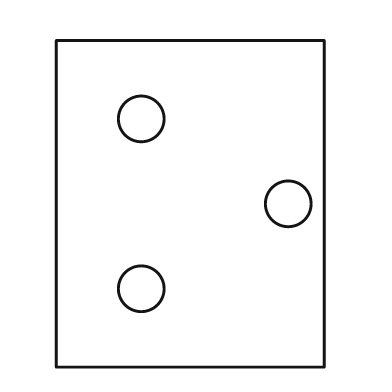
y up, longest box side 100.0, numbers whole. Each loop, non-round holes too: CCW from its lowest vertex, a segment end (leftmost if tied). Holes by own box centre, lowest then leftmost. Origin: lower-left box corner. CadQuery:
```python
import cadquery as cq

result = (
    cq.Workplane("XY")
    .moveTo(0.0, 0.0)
    .lineTo(82.0, 0.0)
    .lineTo(82.0, 100.0)
    .lineTo(0.0, 100.0)
    .close()
    .moveTo(26.0, 24.0)
    .circle(7.0)
    .moveTo(71.0, 50.0)
    .circle(7.0)
    .moveTo(26.0, 76.0)
    .circle(7.0)
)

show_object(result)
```